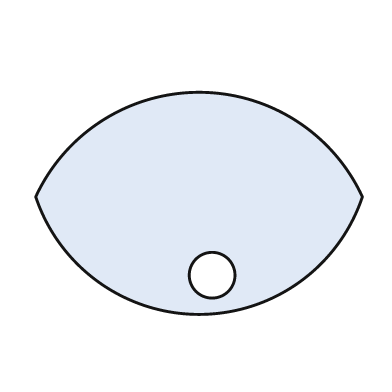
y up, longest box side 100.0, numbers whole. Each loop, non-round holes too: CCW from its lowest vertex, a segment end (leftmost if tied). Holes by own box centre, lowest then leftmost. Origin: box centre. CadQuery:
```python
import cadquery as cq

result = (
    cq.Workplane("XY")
    .moveTo(-50.0, 2.0)
    .threePointArc((0.0, -34.0), (50.0, 2.0))
    .threePointArc((0.0, 34.0), (-50.0, 2.0))
    .close()
    .moveTo(4.0, -22.0)
    .circle(7.0)
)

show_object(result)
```